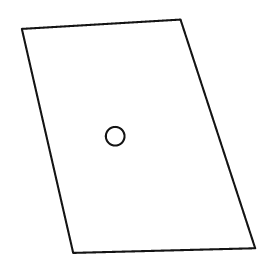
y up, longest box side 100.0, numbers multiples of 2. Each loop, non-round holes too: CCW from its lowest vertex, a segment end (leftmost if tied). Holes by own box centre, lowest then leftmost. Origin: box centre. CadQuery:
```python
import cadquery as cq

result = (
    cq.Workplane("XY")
    .moveTo(-28.0, -50.0)
    .lineTo(50.0, -48.0)
    .lineTo(18.0, 50.0)
    .lineTo(-50.0, 46.0)
    .close()
    .moveTo(-10.0, 0.0)
    .circle(4.0)
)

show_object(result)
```